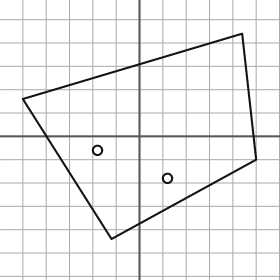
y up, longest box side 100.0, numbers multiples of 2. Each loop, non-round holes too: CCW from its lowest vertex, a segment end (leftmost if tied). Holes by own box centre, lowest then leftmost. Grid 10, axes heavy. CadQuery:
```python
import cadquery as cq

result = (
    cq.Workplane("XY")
    .moveTo(-12.0, -44.0)
    .lineTo(50.0, -10.0)
    .lineTo(44.0, 44.0)
    .lineTo(-50.0, 16.0)
    .close()
    .moveTo(12.0, -18.0)
    .circle(2.0)
    .moveTo(-18.0, -6.0)
    .circle(2.0)
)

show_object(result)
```